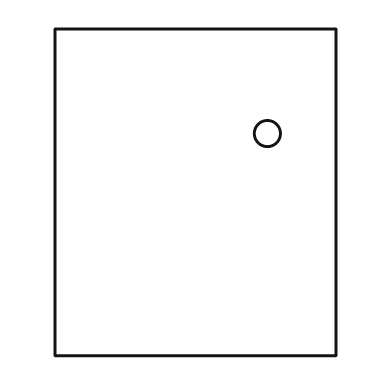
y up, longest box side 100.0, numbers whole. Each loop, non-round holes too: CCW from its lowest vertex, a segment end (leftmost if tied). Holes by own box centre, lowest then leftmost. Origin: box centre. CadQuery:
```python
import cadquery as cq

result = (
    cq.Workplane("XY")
    .moveTo(-43.0, -50.0)
    .lineTo(43.0, -50.0)
    .lineTo(43.0, 50.0)
    .lineTo(-43.0, 50.0)
    .close()
    .moveTo(22.0, 18.0)
    .circle(4.0)
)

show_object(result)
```